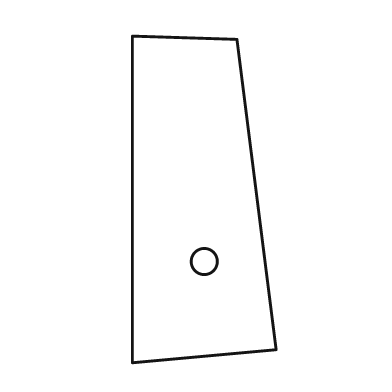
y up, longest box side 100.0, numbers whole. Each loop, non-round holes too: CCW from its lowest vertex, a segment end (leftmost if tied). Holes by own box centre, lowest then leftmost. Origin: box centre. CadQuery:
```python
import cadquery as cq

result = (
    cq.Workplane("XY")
    .moveTo(-22.0, -50.0)
    .lineTo(22.0, -46.0)
    .lineTo(10.0, 49.0)
    .lineTo(-22.0, 50.0)
    .close()
    .moveTo(0.0, -19.0)
    .circle(4.0)
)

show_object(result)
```